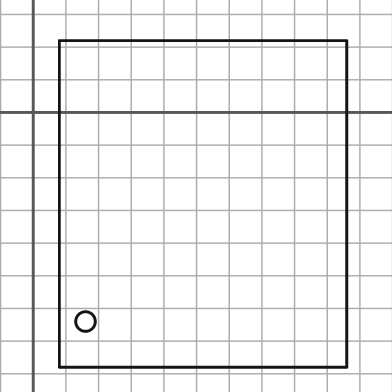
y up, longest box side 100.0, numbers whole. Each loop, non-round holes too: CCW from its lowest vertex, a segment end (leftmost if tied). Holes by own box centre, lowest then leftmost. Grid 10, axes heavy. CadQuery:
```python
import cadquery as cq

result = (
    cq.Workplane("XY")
    .moveTo(8.0, -78.0)
    .lineTo(96.0, -78.0)
    .lineTo(96.0, 22.0)
    .lineTo(8.0, 22.0)
    .close()
    .moveTo(16.0, -64.0)
    .circle(3.0)
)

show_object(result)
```